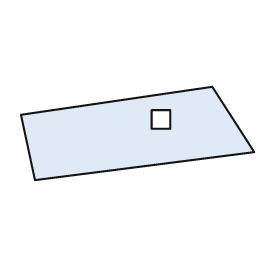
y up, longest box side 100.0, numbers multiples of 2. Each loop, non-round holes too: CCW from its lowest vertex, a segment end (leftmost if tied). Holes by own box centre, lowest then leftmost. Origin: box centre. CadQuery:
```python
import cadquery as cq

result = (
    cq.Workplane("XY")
    .moveTo(-44.0, -20.0)
    .lineTo(50.0, -8.0)
    .lineTo(32.0, 20.0)
    .lineTo(-50.0, 8.0)
    .close()
    .moveTo(6.0, 2.0)
    .lineTo(14.0, 2.0)
    .lineTo(14.0, 10.0)
    .lineTo(6.0, 10.0)
    .close()
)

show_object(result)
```